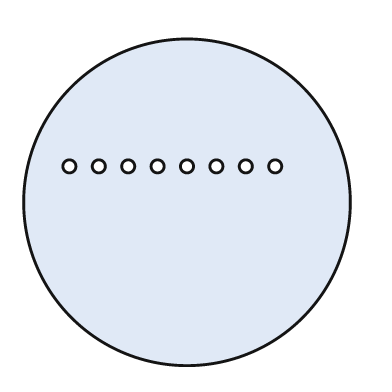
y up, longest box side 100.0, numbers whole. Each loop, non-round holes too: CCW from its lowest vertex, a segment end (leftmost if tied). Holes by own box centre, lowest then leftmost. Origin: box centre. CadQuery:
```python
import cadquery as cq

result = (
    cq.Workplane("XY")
    .moveTo(0.0, 0.0)
    .circle(50.0)
    .moveTo(-36.0, 11.0)
    .circle(2.0)
    .moveTo(-27.0, 11.0)
    .circle(2.0)
    .moveTo(-18.0, 11.0)
    .circle(2.0)
    .moveTo(-9.0, 11.0)
    .circle(2.0)
    .moveTo(0.0, 11.0)
    .circle(2.0)
    .moveTo(9.0, 11.0)
    .circle(2.0)
    .moveTo(18.0, 11.0)
    .circle(2.0)
    .moveTo(27.0, 11.0)
    .circle(2.0)
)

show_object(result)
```